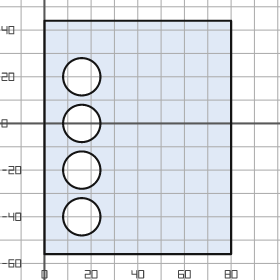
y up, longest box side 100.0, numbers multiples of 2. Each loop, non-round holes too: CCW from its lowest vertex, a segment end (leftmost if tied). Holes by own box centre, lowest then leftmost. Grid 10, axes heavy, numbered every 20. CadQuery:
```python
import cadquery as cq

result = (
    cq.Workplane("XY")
    .moveTo(0.0, -56.0)
    .lineTo(80.0, -56.0)
    .lineTo(80.0, 44.0)
    .lineTo(0.0, 44.0)
    .close()
    .moveTo(16.0, -40.0)
    .circle(8.0)
    .moveTo(16.0, -20.0)
    .circle(8.0)
    .moveTo(16.0, 0.0)
    .circle(8.0)
    .moveTo(16.0, 20.0)
    .circle(8.0)
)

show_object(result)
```